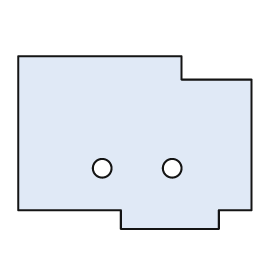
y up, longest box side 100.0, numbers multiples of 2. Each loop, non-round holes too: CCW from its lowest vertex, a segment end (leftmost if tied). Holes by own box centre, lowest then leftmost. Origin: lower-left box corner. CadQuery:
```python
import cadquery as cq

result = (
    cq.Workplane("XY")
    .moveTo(44.0, 0.0)
    .lineTo(86.0, 0.0)
    .lineTo(86.0, 8.0)
    .lineTo(100.0, 8.0)
    .lineTo(100.0, 64.0)
    .lineTo(70.0, 64.0)
    .lineTo(70.0, 74.0)
    .lineTo(0.0, 74.0)
    .lineTo(0.0, 8.0)
    .lineTo(44.0, 8.0)
    .close()
    .moveTo(36.0, 26.0)
    .circle(4.0)
    .moveTo(66.0, 26.0)
    .circle(4.0)
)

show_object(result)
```